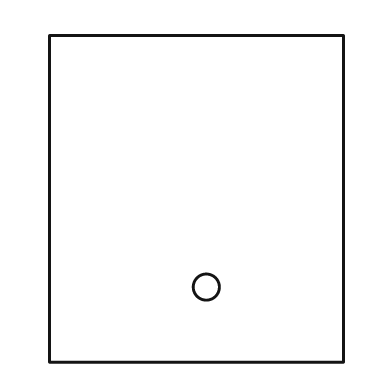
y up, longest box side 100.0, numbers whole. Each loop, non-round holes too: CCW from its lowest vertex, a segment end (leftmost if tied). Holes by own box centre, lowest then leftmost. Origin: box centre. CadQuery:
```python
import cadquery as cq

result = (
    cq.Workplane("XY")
    .moveTo(-45.0, -50.0)
    .lineTo(45.0, -50.0)
    .lineTo(45.0, 50.0)
    .lineTo(-45.0, 50.0)
    .close()
    .moveTo(3.0, -27.0)
    .circle(4.0)
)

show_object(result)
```